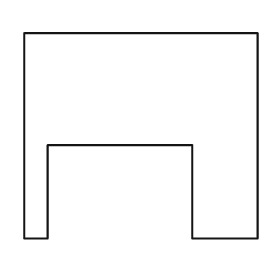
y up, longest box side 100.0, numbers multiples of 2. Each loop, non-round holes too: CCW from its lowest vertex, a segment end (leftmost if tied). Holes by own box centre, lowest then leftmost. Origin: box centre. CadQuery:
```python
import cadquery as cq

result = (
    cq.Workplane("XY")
    .moveTo(-50.0, -44.0)
    .lineTo(-40.0, -44.0)
    .lineTo(-40.0, -4.0)
    .lineTo(22.0, -4.0)
    .lineTo(22.0, -44.0)
    .lineTo(50.0, -44.0)
    .lineTo(50.0, 44.0)
    .lineTo(-50.0, 44.0)
    .close()
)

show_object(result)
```